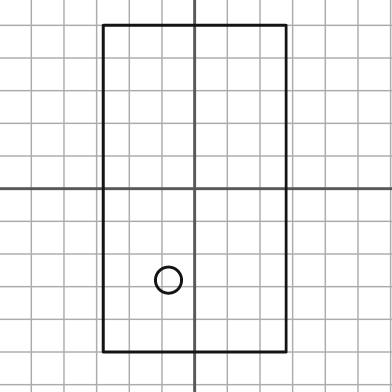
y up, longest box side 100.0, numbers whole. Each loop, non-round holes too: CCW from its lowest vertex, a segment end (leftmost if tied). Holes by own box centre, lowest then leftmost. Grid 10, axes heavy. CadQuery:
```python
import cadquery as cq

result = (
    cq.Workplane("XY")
    .moveTo(-28.0, -50.0)
    .lineTo(28.0, -50.0)
    .lineTo(28.0, 50.0)
    .lineTo(-28.0, 50.0)
    .close()
    .moveTo(-8.0, -28.0)
    .circle(4.0)
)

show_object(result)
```